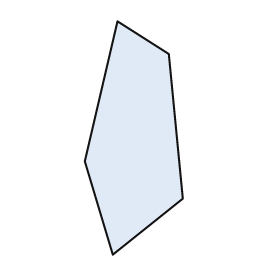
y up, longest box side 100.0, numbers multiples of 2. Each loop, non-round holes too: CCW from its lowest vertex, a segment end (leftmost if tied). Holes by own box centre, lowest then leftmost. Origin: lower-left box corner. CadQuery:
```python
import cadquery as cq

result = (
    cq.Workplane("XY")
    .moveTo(12.0, 0.0)
    .lineTo(42.0, 24.0)
    .lineTo(36.0, 86.0)
    .lineTo(14.0, 100.0)
    .lineTo(0.0, 40.0)
    .close()
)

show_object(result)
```